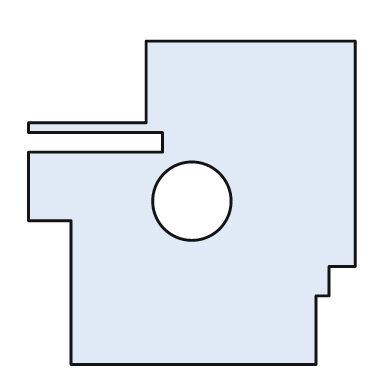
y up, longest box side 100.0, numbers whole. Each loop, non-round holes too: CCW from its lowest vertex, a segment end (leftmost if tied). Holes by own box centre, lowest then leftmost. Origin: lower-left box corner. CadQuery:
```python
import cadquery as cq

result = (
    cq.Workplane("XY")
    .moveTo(13.0, 0.0)
    .lineTo(88.0, 0.0)
    .lineTo(88.0, 21.0)
    .lineTo(92.0, 21.0)
    .lineTo(92.0, 30.0)
    .lineTo(100.0, 30.0)
    .lineTo(100.0, 99.0)
    .lineTo(36.0, 99.0)
    .lineTo(36.0, 74.0)
    .lineTo(0.0, 74.0)
    .lineTo(0.0, 71.0)
    .lineTo(41.0, 71.0)
    .lineTo(41.0, 65.0)
    .lineTo(0.0, 65.0)
    .lineTo(0.0, 44.0)
    .lineTo(13.0, 44.0)
    .close()
    .moveTo(50.0, 50.0)
    .circle(12.0)
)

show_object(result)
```